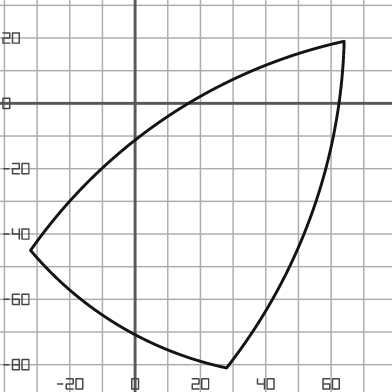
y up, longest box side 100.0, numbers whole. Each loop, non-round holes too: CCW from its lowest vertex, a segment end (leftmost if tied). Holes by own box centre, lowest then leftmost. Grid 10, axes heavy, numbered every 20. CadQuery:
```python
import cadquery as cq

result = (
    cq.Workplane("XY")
    .moveTo(28.0, -81.0)
    .threePointArc((54.0, -34.0), (64.0, 19.0))
    .threePointArc((10.0, -4.0), (-32.0, -45.0))
    .threePointArc((-5.0, -68.0), (28.0, -81.0))
    .close()
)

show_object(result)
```